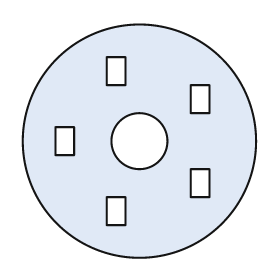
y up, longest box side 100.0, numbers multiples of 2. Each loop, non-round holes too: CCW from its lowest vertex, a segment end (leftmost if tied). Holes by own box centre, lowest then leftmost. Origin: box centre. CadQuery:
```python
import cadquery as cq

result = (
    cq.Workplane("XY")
    .moveTo(0.0, 0.0)
    .circle(50.0)
    .moveTo(-14.0, -36.0)
    .lineTo(-6.0, -36.0)
    .lineTo(-6.0, -24.0)
    .lineTo(-14.0, -24.0)
    .close()
    .moveTo(22.0, -24.0)
    .lineTo(30.0, -24.0)
    .lineTo(30.0, -12.0)
    .lineTo(22.0, -12.0)
    .close()
    .moveTo(-36.0, -6.0)
    .lineTo(-28.0, -6.0)
    .lineTo(-28.0, 6.0)
    .lineTo(-36.0, 6.0)
    .close()
    .moveTo(0.0, 0.0)
    .circle(12.0)
    .moveTo(22.0, 12.0)
    .lineTo(30.0, 12.0)
    .lineTo(30.0, 24.0)
    .lineTo(22.0, 24.0)
    .close()
    .moveTo(-14.0, 24.0)
    .lineTo(-6.0, 24.0)
    .lineTo(-6.0, 36.0)
    .lineTo(-14.0, 36.0)
    .close()
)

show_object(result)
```